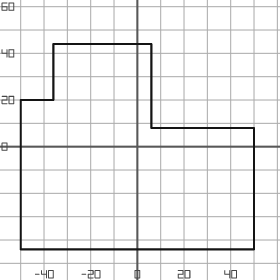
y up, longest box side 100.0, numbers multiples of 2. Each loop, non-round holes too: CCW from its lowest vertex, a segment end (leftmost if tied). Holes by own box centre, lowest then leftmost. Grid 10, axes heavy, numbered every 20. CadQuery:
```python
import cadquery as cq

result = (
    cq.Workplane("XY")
    .moveTo(-50.0, -44.0)
    .lineTo(50.0, -44.0)
    .lineTo(50.0, 8.0)
    .lineTo(6.0, 8.0)
    .lineTo(6.0, 44.0)
    .lineTo(-36.0, 44.0)
    .lineTo(-36.0, 20.0)
    .lineTo(-50.0, 20.0)
    .close()
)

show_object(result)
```